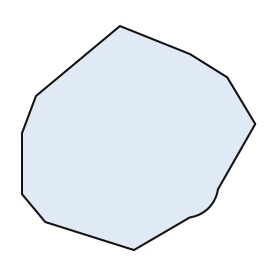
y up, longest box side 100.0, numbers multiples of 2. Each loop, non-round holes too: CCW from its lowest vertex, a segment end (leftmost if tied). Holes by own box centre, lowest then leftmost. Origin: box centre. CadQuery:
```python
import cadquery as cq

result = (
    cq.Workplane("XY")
    .moveTo(-2.0, -48.0)
    .lineTo(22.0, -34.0)
    .threePointArc((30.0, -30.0), (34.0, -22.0))
    .lineTo(50.0, 6.0)
    .lineTo(38.0, 26.0)
    .lineTo(22.0, 36.0)
    .lineTo(-8.0, 48.0)
    .lineTo(-44.0, 18.0)
    .lineTo(-50.0, 2.0)
    .lineTo(-50.0, -24.0)
    .lineTo(-40.0, -36.0)
    .close()
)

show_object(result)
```